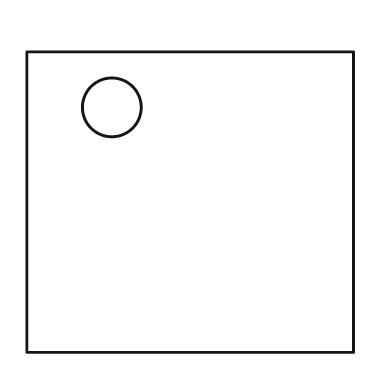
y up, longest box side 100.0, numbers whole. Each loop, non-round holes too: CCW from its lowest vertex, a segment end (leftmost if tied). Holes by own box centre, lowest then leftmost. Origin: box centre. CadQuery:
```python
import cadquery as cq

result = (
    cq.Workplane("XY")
    .moveTo(-50.0, -46.0)
    .lineTo(50.0, -46.0)
    .lineTo(50.0, 46.0)
    .lineTo(-50.0, 46.0)
    .close()
    .moveTo(-24.0, 29.0)
    .circle(9.0)
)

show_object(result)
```